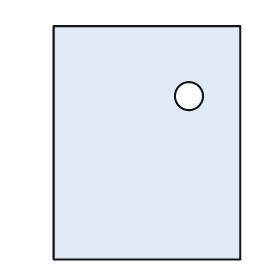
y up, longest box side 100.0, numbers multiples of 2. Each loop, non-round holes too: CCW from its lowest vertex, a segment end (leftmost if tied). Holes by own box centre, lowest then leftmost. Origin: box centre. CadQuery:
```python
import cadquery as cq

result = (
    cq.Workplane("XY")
    .moveTo(-40.0, -50.0)
    .lineTo(40.0, -50.0)
    .lineTo(40.0, 50.0)
    .lineTo(-40.0, 50.0)
    .close()
    .moveTo(18.0, 20.0)
    .circle(6.0)
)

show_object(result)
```